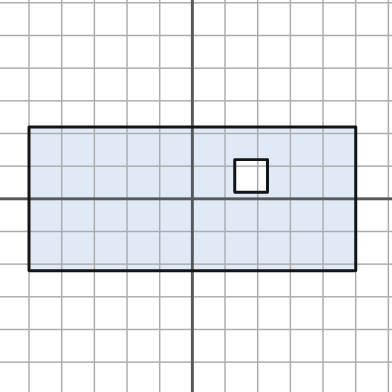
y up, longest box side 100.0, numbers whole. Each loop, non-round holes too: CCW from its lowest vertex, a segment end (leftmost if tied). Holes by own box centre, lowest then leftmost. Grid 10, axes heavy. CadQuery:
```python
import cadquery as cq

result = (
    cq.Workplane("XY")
    .moveTo(-50.0, -22.0)
    .lineTo(50.0, -22.0)
    .lineTo(50.0, 22.0)
    .lineTo(-50.0, 22.0)
    .close()
    .moveTo(13.0, 2.0)
    .lineTo(23.0, 2.0)
    .lineTo(23.0, 12.0)
    .lineTo(13.0, 12.0)
    .close()
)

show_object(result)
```